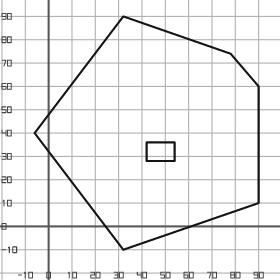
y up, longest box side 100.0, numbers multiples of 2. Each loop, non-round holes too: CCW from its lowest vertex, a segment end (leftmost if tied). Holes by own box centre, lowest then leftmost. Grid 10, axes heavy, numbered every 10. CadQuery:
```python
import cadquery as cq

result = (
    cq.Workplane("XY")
    .moveTo(32.0, -10.0)
    .lineTo(90.0, 10.0)
    .lineTo(90.0, 60.0)
    .lineTo(78.0, 74.0)
    .lineTo(32.0, 90.0)
    .lineTo(-6.0, 40.0)
    .close()
    .moveTo(42.0, 28.0)
    .lineTo(54.0, 28.0)
    .lineTo(54.0, 36.0)
    .lineTo(42.0, 36.0)
    .close()
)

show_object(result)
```